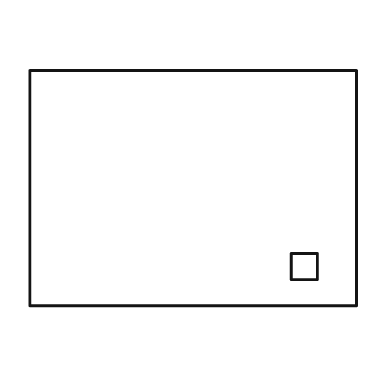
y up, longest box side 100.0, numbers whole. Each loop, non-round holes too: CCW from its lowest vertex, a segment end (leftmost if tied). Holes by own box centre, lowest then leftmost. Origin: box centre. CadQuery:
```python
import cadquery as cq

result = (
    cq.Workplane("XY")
    .moveTo(-50.0, -36.0)
    .lineTo(50.0, -36.0)
    .lineTo(50.0, 36.0)
    .lineTo(-50.0, 36.0)
    .close()
    .moveTo(30.0, -28.0)
    .lineTo(38.0, -28.0)
    .lineTo(38.0, -20.0)
    .lineTo(30.0, -20.0)
    .close()
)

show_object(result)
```